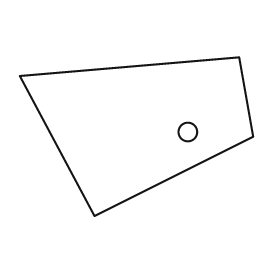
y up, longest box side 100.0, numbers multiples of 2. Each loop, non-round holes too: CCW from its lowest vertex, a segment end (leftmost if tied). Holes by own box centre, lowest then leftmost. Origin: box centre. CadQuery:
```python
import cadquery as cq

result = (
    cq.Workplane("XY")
    .moveTo(-18.0, -34.0)
    .lineTo(50.0, 0.0)
    .lineTo(44.0, 34.0)
    .lineTo(-50.0, 26.0)
    .close()
    .moveTo(22.0, 2.0)
    .circle(4.0)
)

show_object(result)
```